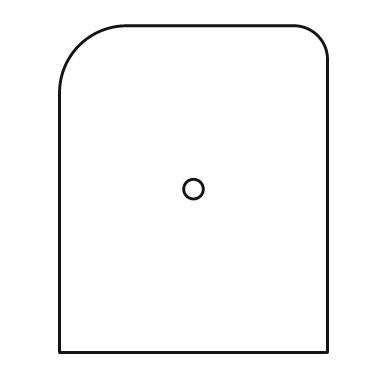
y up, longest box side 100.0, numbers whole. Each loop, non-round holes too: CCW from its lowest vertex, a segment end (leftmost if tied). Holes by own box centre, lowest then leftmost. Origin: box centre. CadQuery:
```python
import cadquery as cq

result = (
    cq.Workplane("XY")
    .moveTo(-41.0, -50.0)
    .lineTo(41.0, -50.0)
    .lineTo(41.0, 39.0)
    .threePointArc((38.0, 47.0), (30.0, 50.0))
    .lineTo(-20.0, 50.0)
    .threePointArc((-35.0, 44.0), (-41.0, 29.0))
    .close()
    .moveTo(0.0, 0.0)
    .circle(3.0)
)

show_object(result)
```